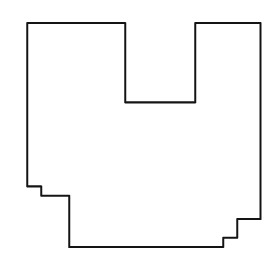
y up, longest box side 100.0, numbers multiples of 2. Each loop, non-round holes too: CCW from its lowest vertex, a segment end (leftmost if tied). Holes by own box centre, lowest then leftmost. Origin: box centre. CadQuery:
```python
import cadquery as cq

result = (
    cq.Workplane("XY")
    .moveTo(-32.0, -48.0)
    .lineTo(34.0, -48.0)
    .lineTo(34.0, -44.0)
    .lineTo(40.0, -44.0)
    .lineTo(40.0, -36.0)
    .lineTo(50.0, -36.0)
    .lineTo(50.0, 48.0)
    .lineTo(22.0, 48.0)
    .lineTo(22.0, 14.0)
    .lineTo(-8.0, 14.0)
    .lineTo(-8.0, 48.0)
    .lineTo(-50.0, 48.0)
    .lineTo(-50.0, -22.0)
    .lineTo(-44.0, -22.0)
    .lineTo(-44.0, -26.0)
    .lineTo(-32.0, -26.0)
    .close()
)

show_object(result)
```